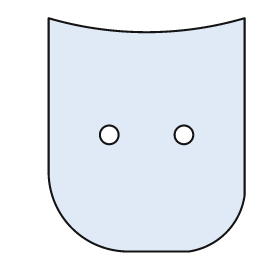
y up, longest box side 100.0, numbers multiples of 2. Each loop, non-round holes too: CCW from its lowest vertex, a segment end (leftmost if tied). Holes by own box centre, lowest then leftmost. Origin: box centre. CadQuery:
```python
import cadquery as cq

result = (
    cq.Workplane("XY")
    .moveTo(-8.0, -50.0)
    .lineTo(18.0, -50.0)
    .threePointArc((34.0, -42.0), (42.0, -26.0))
    .lineTo(42.0, 50.0)
    .threePointArc((0.0, 44.0), (-42.0, 50.0))
    .lineTo(-42.0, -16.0)
    .threePointArc((-32.0, -40.0), (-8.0, -50.0))
    .close()
    .moveTo(-16.0, 0.0)
    .circle(4.0)
    .moveTo(16.0, 0.0)
    .circle(4.0)
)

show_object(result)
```